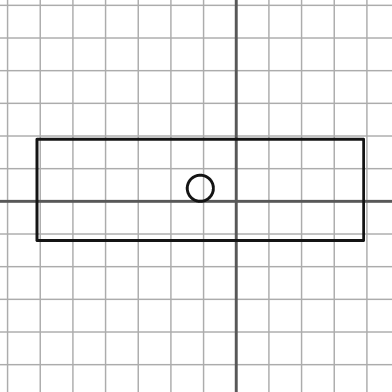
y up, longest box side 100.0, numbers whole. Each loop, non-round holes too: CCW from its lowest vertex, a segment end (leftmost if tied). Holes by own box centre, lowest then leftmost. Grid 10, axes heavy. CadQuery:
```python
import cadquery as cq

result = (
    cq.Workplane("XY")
    .moveTo(-61.0, -12.0)
    .lineTo(39.0, -12.0)
    .lineTo(39.0, 19.0)
    .lineTo(-61.0, 19.0)
    .close()
    .moveTo(-11.0, 4.0)
    .circle(4.0)
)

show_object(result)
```